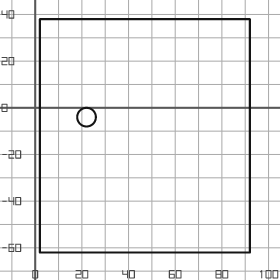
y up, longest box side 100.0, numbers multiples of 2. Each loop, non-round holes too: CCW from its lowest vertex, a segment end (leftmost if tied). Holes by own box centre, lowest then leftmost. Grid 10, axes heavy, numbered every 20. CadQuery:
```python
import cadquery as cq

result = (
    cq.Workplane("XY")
    .moveTo(2.0, -62.0)
    .lineTo(92.0, -62.0)
    .lineTo(92.0, 38.0)
    .lineTo(2.0, 38.0)
    .close()
    .moveTo(22.0, -4.0)
    .circle(4.0)
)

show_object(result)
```